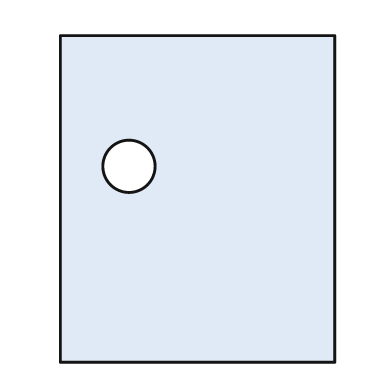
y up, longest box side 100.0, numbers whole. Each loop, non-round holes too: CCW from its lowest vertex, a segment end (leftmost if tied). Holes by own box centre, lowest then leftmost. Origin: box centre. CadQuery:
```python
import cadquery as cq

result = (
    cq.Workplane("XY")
    .moveTo(-42.0, -50.0)
    .lineTo(42.0, -50.0)
    .lineTo(42.0, 50.0)
    .lineTo(-42.0, 50.0)
    .close()
    .moveTo(-21.0, 10.0)
    .circle(8.0)
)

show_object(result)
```